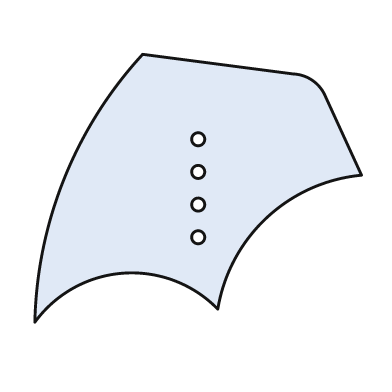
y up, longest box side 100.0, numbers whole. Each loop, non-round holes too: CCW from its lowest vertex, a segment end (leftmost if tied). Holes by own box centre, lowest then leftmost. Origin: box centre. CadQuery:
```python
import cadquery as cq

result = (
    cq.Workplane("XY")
    .moveTo(-50.0, -41.0)
    .threePointArc((-23.0, -26.0), (6.0, -37.0))
    .threePointArc((21.0, -9.0), (50.0, 4.0))
    .lineTo(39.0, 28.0)
    .threePointArc((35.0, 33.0), (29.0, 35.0))
    .lineTo(-17.0, 41.0)
    .threePointArc((-41.0, 3.0), (-50.0, -41.0))
    .close()
    .moveTo(0.0, -15.0)
    .circle(2.0)
    .moveTo(0.0, -5.0)
    .circle(2.0)
    .moveTo(0.0, 5.0)
    .circle(2.0)
    .moveTo(0.0, 15.0)
    .circle(2.0)
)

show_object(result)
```